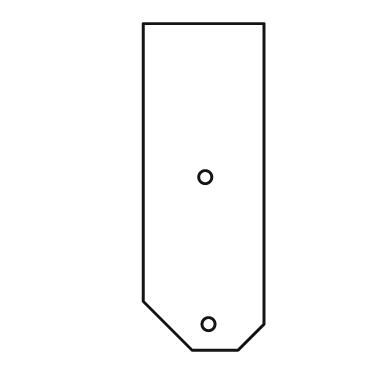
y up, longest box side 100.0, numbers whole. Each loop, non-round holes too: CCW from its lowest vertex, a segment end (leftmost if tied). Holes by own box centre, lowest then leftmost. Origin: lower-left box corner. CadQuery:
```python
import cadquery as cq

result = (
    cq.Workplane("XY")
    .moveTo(15.0, 0.0)
    .lineTo(29.0, 0.0)
    .lineTo(37.0, 8.0)
    .lineTo(37.0, 100.0)
    .lineTo(0.0, 100.0)
    .lineTo(0.0, 15.0)
    .close()
    .moveTo(20.0, 8.0)
    .circle(2.0)
    .moveTo(19.0, 53.0)
    .circle(2.0)
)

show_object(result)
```